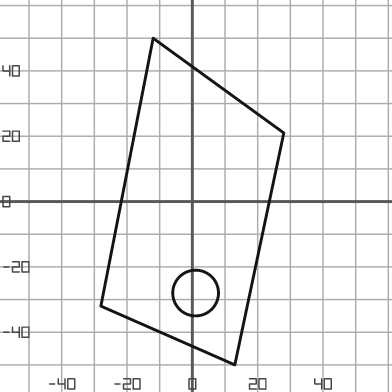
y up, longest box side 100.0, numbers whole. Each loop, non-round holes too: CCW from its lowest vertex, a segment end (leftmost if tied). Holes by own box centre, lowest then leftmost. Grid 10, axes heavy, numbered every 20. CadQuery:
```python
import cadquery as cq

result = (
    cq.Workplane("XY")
    .moveTo(13.0, -50.0)
    .lineTo(28.0, 21.0)
    .lineTo(-12.0, 50.0)
    .lineTo(-28.0, -32.0)
    .close()
    .moveTo(1.0, -28.0)
    .circle(7.0)
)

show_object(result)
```